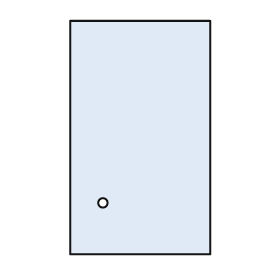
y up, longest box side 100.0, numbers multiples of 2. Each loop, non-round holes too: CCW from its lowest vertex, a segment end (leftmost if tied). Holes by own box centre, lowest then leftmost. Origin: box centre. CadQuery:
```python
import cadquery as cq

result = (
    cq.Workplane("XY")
    .moveTo(-30.0, -50.0)
    .lineTo(30.0, -50.0)
    .lineTo(30.0, 50.0)
    .lineTo(-30.0, 50.0)
    .close()
    .moveTo(-16.0, -28.0)
    .circle(2.0)
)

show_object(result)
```